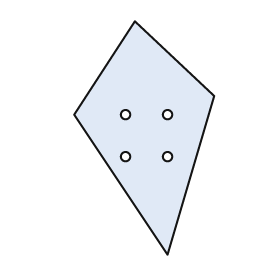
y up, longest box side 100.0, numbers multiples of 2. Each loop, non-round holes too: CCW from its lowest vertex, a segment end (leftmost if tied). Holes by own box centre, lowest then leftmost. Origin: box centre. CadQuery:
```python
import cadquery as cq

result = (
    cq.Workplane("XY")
    .moveTo(10.0, -50.0)
    .lineTo(30.0, 18.0)
    .lineTo(-4.0, 50.0)
    .lineTo(-30.0, 10.0)
    .close()
    .moveTo(-8.0, -8.0)
    .circle(2.0)
    .moveTo(10.0, -8.0)
    .circle(2.0)
    .moveTo(-8.0, 10.0)
    .circle(2.0)
    .moveTo(10.0, 10.0)
    .circle(2.0)
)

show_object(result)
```